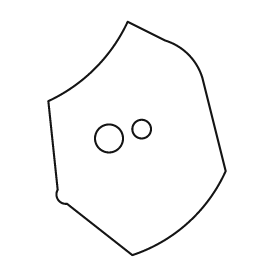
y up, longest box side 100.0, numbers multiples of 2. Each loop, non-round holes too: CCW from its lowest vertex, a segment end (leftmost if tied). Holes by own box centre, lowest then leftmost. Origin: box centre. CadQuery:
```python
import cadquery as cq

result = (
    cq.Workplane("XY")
    .moveTo(-2.0, -50.0)
    .threePointArc((22.0, -36.0), (38.0, -14.0))
    .lineTo(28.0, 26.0)
    .threePointArc((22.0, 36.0), (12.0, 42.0))
    .lineTo(-4.0, 50.0)
    .threePointArc((-18.0, 30.0), (-38.0, 16.0))
    .lineTo(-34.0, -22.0)
    .threePointArc((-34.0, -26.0), (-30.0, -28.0))
    .close()
    .moveTo(-12.0, 0.0)
    .circle(6.0)
    .moveTo(2.0, 4.0)
    .circle(4.0)
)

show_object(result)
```